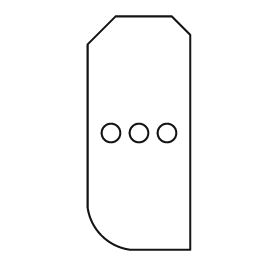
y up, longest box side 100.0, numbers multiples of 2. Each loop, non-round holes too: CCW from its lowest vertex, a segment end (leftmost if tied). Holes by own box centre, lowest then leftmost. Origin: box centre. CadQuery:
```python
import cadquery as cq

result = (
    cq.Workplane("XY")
    .moveTo(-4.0, -50.0)
    .lineTo(22.0, -50.0)
    .lineTo(22.0, 42.0)
    .lineTo(14.0, 50.0)
    .lineTo(-10.0, 50.0)
    .lineTo(-22.0, 38.0)
    .lineTo(-22.0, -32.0)
    .threePointArc((-16.0, -44.0), (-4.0, -50.0))
    .close()
    .moveTo(-12.0, 0.0)
    .circle(4.0)
    .moveTo(0.0, 0.0)
    .circle(4.0)
    .moveTo(12.0, 0.0)
    .circle(4.0)
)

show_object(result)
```